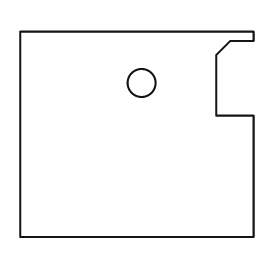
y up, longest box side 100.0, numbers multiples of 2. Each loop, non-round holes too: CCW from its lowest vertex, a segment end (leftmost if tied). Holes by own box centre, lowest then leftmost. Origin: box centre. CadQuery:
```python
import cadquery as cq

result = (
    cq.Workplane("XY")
    .moveTo(-50.0, -44.0)
    .lineTo(50.0, -44.0)
    .lineTo(50.0, 8.0)
    .lineTo(34.0, 8.0)
    .lineTo(34.0, 34.0)
    .lineTo(40.0, 40.0)
    .lineTo(50.0, 40.0)
    .lineTo(50.0, 44.0)
    .lineTo(-50.0, 44.0)
    .close()
    .moveTo(2.0, 22.0)
    .circle(6.0)
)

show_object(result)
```